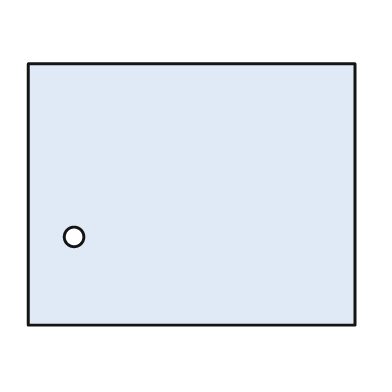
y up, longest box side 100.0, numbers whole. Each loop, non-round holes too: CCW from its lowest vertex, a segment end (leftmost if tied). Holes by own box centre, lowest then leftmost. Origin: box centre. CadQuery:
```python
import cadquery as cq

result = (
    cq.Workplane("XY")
    .moveTo(-50.0, -40.0)
    .lineTo(50.0, -40.0)
    .lineTo(50.0, 40.0)
    .lineTo(-50.0, 40.0)
    .close()
    .moveTo(-36.0, -13.0)
    .circle(3.0)
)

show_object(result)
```